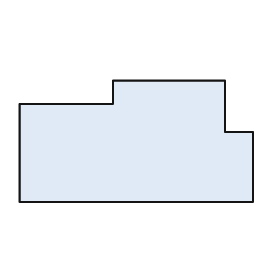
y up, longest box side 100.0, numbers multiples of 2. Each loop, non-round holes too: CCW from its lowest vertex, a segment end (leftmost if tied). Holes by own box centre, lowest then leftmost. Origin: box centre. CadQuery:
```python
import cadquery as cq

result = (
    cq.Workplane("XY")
    .moveTo(-50.0, -26.0)
    .lineTo(50.0, -26.0)
    .lineTo(50.0, 4.0)
    .lineTo(38.0, 4.0)
    .lineTo(38.0, 26.0)
    .lineTo(-10.0, 26.0)
    .lineTo(-10.0, 16.0)
    .lineTo(-50.0, 16.0)
    .close()
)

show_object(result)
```